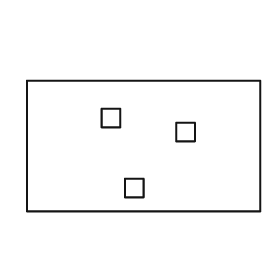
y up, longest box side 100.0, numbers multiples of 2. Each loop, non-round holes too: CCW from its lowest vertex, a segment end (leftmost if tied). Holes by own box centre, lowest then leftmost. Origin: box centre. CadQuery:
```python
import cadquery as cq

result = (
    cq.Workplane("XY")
    .moveTo(-50.0, -28.0)
    .lineTo(50.0, -28.0)
    .lineTo(50.0, 28.0)
    .lineTo(-50.0, 28.0)
    .close()
    .moveTo(-8.0, -22.0)
    .lineTo(0.0, -22.0)
    .lineTo(0.0, -14.0)
    .lineTo(-8.0, -14.0)
    .close()
    .moveTo(14.0, 2.0)
    .lineTo(22.0, 2.0)
    .lineTo(22.0, 10.0)
    .lineTo(14.0, 10.0)
    .close()
    .moveTo(-18.0, 8.0)
    .lineTo(-10.0, 8.0)
    .lineTo(-10.0, 16.0)
    .lineTo(-18.0, 16.0)
    .close()
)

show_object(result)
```